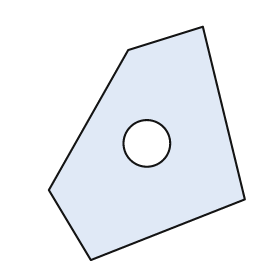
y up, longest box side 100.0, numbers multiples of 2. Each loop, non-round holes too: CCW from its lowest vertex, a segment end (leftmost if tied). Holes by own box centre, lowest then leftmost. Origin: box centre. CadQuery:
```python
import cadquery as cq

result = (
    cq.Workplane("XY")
    .moveTo(-24.0, -50.0)
    .lineTo(42.0, -24.0)
    .lineTo(24.0, 50.0)
    .lineTo(-8.0, 40.0)
    .lineTo(-42.0, -20.0)
    .close()
    .moveTo(0.0, 0.0)
    .circle(10.0)
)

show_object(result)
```